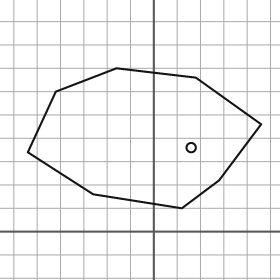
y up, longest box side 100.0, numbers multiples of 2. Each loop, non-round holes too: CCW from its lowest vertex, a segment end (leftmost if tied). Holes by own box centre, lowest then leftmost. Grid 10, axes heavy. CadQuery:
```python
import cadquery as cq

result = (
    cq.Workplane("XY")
    .moveTo(12.0, 10.0)
    .lineTo(28.0, 22.0)
    .lineTo(46.0, 46.0)
    .lineTo(18.0, 66.0)
    .lineTo(-16.0, 70.0)
    .lineTo(-42.0, 60.0)
    .lineTo(-54.0, 34.0)
    .lineTo(-26.0, 16.0)
    .close()
    .moveTo(16.0, 36.0)
    .circle(2.0)
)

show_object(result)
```